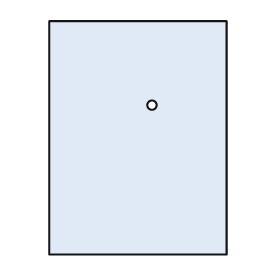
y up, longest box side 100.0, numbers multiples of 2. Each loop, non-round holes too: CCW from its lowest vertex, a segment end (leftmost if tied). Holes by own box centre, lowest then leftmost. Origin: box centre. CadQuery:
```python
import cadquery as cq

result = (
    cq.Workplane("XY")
    .moveTo(-38.0, -50.0)
    .lineTo(38.0, -50.0)
    .lineTo(38.0, 50.0)
    .lineTo(-38.0, 50.0)
    .close()
    .moveTo(6.0, 14.0)
    .circle(2.0)
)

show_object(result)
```